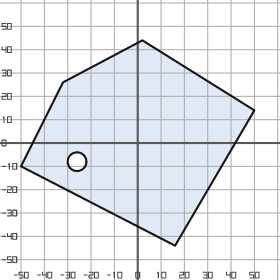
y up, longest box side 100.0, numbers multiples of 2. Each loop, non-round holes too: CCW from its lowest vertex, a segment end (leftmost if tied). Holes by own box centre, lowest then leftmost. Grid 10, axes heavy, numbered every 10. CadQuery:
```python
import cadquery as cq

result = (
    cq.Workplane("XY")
    .moveTo(16.0, -44.0)
    .lineTo(50.0, 14.0)
    .lineTo(2.0, 44.0)
    .lineTo(-32.0, 26.0)
    .lineTo(-50.0, -10.0)
    .close()
    .moveTo(-26.0, -8.0)
    .circle(4.0)
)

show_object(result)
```